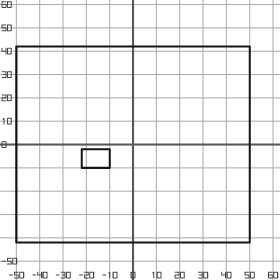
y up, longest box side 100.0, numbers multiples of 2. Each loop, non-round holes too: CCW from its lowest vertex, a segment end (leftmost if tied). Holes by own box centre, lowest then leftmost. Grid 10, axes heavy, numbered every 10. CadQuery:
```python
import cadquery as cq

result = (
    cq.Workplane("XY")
    .moveTo(-50.0, -42.0)
    .lineTo(50.0, -42.0)
    .lineTo(50.0, 42.0)
    .lineTo(-50.0, 42.0)
    .close()
    .moveTo(-22.0, -10.0)
    .lineTo(-10.0, -10.0)
    .lineTo(-10.0, -2.0)
    .lineTo(-22.0, -2.0)
    .close()
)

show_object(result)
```